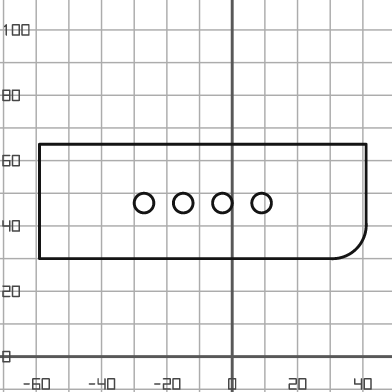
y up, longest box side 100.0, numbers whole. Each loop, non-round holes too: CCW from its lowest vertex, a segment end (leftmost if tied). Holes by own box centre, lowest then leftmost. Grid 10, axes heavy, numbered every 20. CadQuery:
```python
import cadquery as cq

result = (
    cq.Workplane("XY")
    .moveTo(-59.0, 30.0)
    .lineTo(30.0, 30.0)
    .threePointArc((38.0, 33.0), (41.0, 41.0))
    .lineTo(41.0, 65.0)
    .lineTo(-59.0, 65.0)
    .close()
    .moveTo(-27.0, 47.0)
    .circle(3.0)
    .moveTo(-15.0, 47.0)
    .circle(3.0)
    .moveTo(-3.0, 47.0)
    .circle(3.0)
    .moveTo(9.0, 47.0)
    .circle(3.0)
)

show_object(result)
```